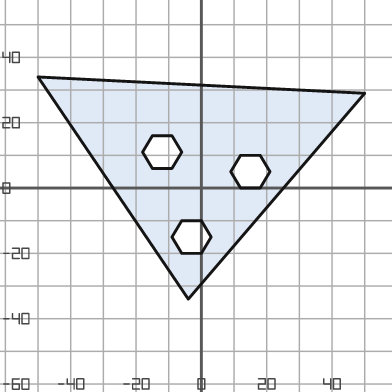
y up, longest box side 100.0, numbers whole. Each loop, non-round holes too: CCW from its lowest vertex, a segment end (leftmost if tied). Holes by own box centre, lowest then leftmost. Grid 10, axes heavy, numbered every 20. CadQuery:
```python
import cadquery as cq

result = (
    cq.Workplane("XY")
    .moveTo(-4.0, -34.0)
    .lineTo(50.0, 29.0)
    .lineTo(-50.0, 34.0)
    .close()
    .moveTo(-6.0, -20.0)
    .lineTo(0.0, -20.0)
    .lineTo(3.0, -15.0)
    .lineTo(0.0, -10.0)
    .lineTo(-6.0, -10.0)
    .lineTo(-9.0, -15.0)
    .close()
    .moveTo(12.0, 0.0)
    .lineTo(18.0, 0.0)
    .lineTo(21.0, 5.0)
    .lineTo(18.0, 10.0)
    .lineTo(12.0, 10.0)
    .lineTo(9.0, 5.0)
    .close()
    .moveTo(-15.0, 6.0)
    .lineTo(-9.0, 6.0)
    .lineTo(-6.0, 11.0)
    .lineTo(-9.0, 16.0)
    .lineTo(-15.0, 16.0)
    .lineTo(-18.0, 11.0)
    .close()
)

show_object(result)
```